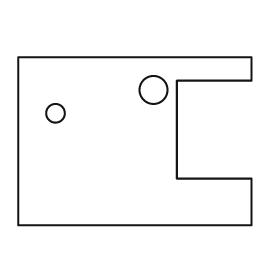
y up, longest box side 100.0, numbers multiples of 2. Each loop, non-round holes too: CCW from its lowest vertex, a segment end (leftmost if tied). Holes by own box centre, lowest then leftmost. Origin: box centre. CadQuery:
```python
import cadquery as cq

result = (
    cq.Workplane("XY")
    .moveTo(-50.0, -36.0)
    .lineTo(50.0, -36.0)
    .lineTo(50.0, -16.0)
    .lineTo(18.0, -16.0)
    .lineTo(18.0, 26.0)
    .lineTo(50.0, 26.0)
    .lineTo(50.0, 36.0)
    .lineTo(-50.0, 36.0)
    .close()
    .moveTo(-34.0, 12.0)
    .circle(4.0)
    .moveTo(8.0, 22.0)
    .circle(6.0)
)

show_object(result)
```